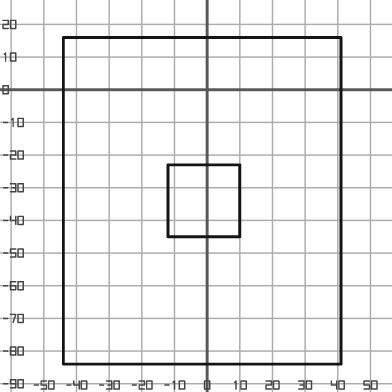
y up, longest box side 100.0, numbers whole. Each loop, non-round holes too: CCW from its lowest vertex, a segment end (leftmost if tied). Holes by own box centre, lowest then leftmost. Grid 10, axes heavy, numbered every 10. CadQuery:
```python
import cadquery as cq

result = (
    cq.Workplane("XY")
    .moveTo(-44.0, -84.0)
    .lineTo(41.0, -84.0)
    .lineTo(41.0, 16.0)
    .lineTo(-44.0, 16.0)
    .close()
    .moveTo(-12.0, -45.0)
    .lineTo(10.0, -45.0)
    .lineTo(10.0, -23.0)
    .lineTo(-12.0, -23.0)
    .close()
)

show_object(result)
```